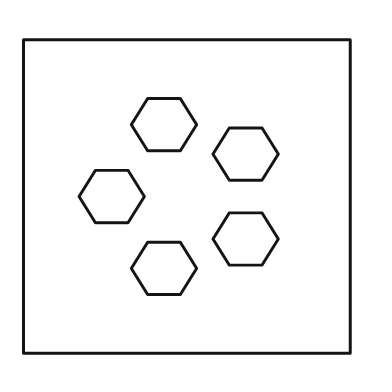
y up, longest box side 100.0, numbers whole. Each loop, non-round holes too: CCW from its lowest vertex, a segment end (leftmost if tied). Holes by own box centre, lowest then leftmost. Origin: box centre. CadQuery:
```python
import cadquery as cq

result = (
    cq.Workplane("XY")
    .moveTo(-50.0, -48.0)
    .lineTo(50.0, -48.0)
    .lineTo(50.0, 48.0)
    .lineTo(-50.0, 48.0)
    .close()
    .moveTo(-12.0, -30.0)
    .lineTo(-2.0, -30.0)
    .lineTo(3.0, -22.0)
    .lineTo(-2.0, -14.0)
    .lineTo(-12.0, -14.0)
    .lineTo(-17.0, -22.0)
    .close()
    .moveTo(13.0, -21.0)
    .lineTo(23.0, -21.0)
    .lineTo(28.0, -13.0)
    .lineTo(23.0, -5.0)
    .lineTo(13.0, -5.0)
    .lineTo(8.0, -13.0)
    .close()
    .moveTo(-28.0, -8.0)
    .lineTo(-18.0, -8.0)
    .lineTo(-13.0, 0.0)
    .lineTo(-18.0, 8.0)
    .lineTo(-28.0, 8.0)
    .lineTo(-33.0, 0.0)
    .close()
    .moveTo(13.0, 5.0)
    .lineTo(23.0, 5.0)
    .lineTo(28.0, 13.0)
    .lineTo(23.0, 21.0)
    .lineTo(13.0, 21.0)
    .lineTo(8.0, 13.0)
    .close()
    .moveTo(-12.0, 14.0)
    .lineTo(-2.0, 14.0)
    .lineTo(3.0, 22.0)
    .lineTo(-2.0, 30.0)
    .lineTo(-12.0, 30.0)
    .lineTo(-17.0, 22.0)
    .close()
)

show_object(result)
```